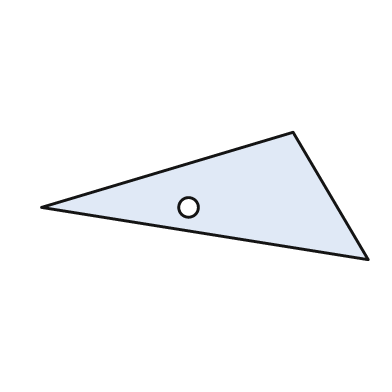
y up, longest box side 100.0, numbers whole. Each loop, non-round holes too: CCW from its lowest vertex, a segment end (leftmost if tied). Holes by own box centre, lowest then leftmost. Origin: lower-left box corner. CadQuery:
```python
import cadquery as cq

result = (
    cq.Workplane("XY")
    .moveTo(100.0, 0.0)
    .lineTo(77.0, 39.0)
    .lineTo(0.0, 16.0)
    .close()
    .moveTo(45.0, 16.0)
    .circle(3.0)
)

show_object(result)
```